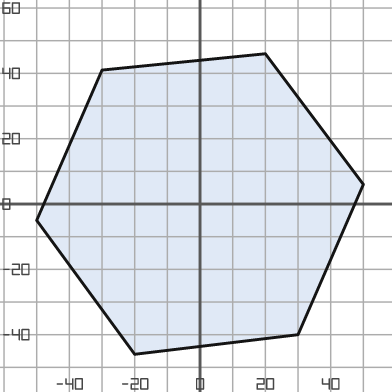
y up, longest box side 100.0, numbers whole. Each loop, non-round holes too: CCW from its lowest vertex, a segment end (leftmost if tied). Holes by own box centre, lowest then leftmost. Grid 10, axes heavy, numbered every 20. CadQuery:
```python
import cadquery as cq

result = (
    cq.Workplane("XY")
    .moveTo(-20.0, -46.0)
    .lineTo(30.0, -40.0)
    .lineTo(50.0, 6.0)
    .lineTo(20.0, 46.0)
    .lineTo(-30.0, 41.0)
    .lineTo(-50.0, -5.0)
    .close()
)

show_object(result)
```